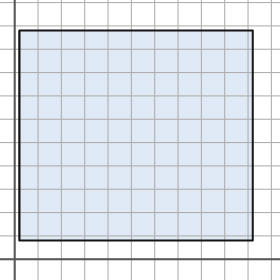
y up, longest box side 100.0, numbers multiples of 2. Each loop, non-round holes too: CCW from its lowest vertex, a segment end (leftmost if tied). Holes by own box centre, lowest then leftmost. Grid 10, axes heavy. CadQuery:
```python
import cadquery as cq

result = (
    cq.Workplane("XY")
    .moveTo(2.0, 8.0)
    .lineTo(102.0, 8.0)
    .lineTo(102.0, 98.0)
    .lineTo(2.0, 98.0)
    .close()
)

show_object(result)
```